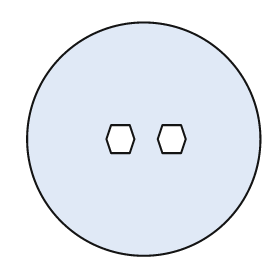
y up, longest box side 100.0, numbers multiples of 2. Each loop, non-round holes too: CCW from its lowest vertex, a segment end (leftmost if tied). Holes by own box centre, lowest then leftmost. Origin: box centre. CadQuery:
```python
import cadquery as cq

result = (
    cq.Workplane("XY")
    .moveTo(0.0, 0.0)
    .circle(50.0)
    .moveTo(-14.0, -6.0)
    .lineTo(-6.0, -6.0)
    .lineTo(-4.0, 0.0)
    .lineTo(-6.0, 6.0)
    .lineTo(-14.0, 6.0)
    .lineTo(-16.0, 0.0)
    .close()
    .moveTo(8.0, -6.0)
    .lineTo(16.0, -6.0)
    .lineTo(18.0, 0.0)
    .lineTo(16.0, 6.0)
    .lineTo(8.0, 6.0)
    .lineTo(6.0, 0.0)
    .close()
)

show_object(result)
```